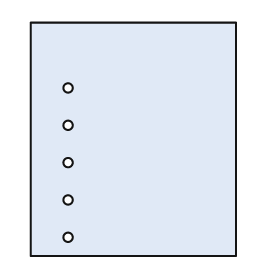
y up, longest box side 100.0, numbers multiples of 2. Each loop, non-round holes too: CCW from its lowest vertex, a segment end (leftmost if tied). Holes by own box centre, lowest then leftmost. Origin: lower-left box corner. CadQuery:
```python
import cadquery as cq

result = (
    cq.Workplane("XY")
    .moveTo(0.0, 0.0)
    .lineTo(88.0, 0.0)
    .lineTo(88.0, 100.0)
    .lineTo(0.0, 100.0)
    .close()
    .moveTo(16.0, 8.0)
    .circle(2.0)
    .moveTo(16.0, 24.0)
    .circle(2.0)
    .moveTo(16.0, 40.0)
    .circle(2.0)
    .moveTo(16.0, 56.0)
    .circle(2.0)
    .moveTo(16.0, 72.0)
    .circle(2.0)
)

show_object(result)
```